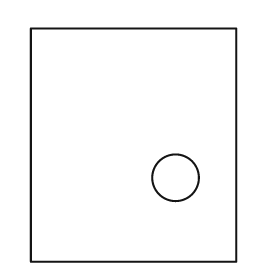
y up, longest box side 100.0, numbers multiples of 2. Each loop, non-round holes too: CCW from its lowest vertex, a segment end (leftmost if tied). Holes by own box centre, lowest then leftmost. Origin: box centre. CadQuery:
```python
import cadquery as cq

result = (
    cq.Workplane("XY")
    .moveTo(-44.0, -50.0)
    .lineTo(44.0, -50.0)
    .lineTo(44.0, 50.0)
    .lineTo(-44.0, 50.0)
    .close()
    .moveTo(18.0, -14.0)
    .circle(10.0)
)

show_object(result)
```